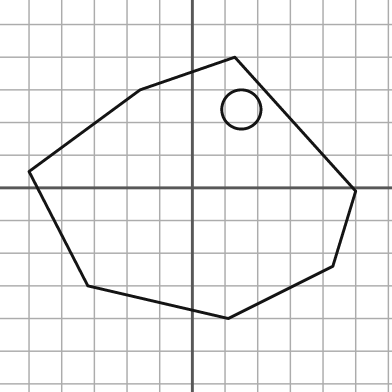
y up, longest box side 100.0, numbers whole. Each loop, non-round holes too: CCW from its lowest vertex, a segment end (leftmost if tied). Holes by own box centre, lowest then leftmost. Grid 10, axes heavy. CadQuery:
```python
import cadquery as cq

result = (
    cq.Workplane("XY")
    .moveTo(11.0, -40.0)
    .lineTo(43.0, -24.0)
    .lineTo(50.0, -1.0)
    .lineTo(13.0, 40.0)
    .lineTo(-16.0, 30.0)
    .lineTo(-50.0, 5.0)
    .lineTo(-32.0, -30.0)
    .close()
    .moveTo(15.0, 24.0)
    .circle(6.0)
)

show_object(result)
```